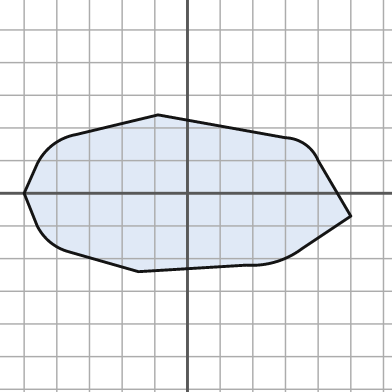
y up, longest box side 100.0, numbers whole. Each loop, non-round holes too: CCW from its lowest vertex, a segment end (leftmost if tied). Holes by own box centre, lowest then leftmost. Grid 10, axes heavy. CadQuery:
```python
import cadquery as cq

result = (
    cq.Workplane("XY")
    .moveTo(-15.0, -24.0)
    .lineTo(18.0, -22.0)
    .threePointArc((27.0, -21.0), (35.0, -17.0))
    .lineTo(50.0, -7.0)
    .lineTo(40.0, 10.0)
    .threePointArc((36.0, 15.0), (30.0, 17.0))
    .lineTo(-9.0, 24.0)
    .lineTo(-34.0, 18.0)
    .threePointArc((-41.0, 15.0), (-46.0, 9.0))
    .lineTo(-50.0, 0.0)
    .lineTo(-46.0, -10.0)
    .threePointArc((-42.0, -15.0), (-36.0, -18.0))
    .close()
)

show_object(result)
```